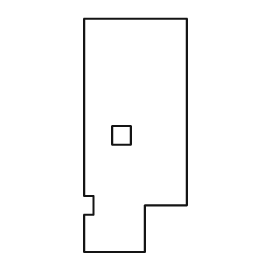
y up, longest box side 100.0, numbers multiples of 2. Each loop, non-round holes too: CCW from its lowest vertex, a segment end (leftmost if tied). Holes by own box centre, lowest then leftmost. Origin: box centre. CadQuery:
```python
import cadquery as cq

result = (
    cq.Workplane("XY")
    .moveTo(-22.0, -50.0)
    .lineTo(4.0, -50.0)
    .lineTo(4.0, -30.0)
    .lineTo(22.0, -30.0)
    .lineTo(22.0, 50.0)
    .lineTo(-22.0, 50.0)
    .lineTo(-22.0, -26.0)
    .lineTo(-18.0, -26.0)
    .lineTo(-18.0, -34.0)
    .lineTo(-22.0, -34.0)
    .close()
    .moveTo(-10.0, -4.0)
    .lineTo(-2.0, -4.0)
    .lineTo(-2.0, 4.0)
    .lineTo(-10.0, 4.0)
    .close()
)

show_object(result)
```